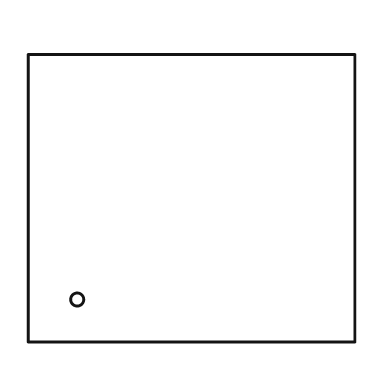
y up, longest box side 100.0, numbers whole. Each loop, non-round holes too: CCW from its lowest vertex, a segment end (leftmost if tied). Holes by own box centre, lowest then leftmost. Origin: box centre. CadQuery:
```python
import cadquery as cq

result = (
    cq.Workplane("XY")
    .moveTo(-50.0, -44.0)
    .lineTo(50.0, -44.0)
    .lineTo(50.0, 44.0)
    .lineTo(-50.0, 44.0)
    .close()
    .moveTo(-35.0, -31.0)
    .circle(2.0)
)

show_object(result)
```